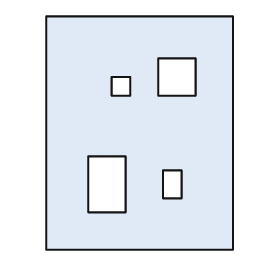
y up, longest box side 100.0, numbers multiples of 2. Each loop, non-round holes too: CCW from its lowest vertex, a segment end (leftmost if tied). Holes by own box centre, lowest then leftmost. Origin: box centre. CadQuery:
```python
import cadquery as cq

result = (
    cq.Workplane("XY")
    .moveTo(-40.0, -50.0)
    .lineTo(40.0, -50.0)
    .lineTo(40.0, 50.0)
    .lineTo(-40.0, 50.0)
    .close()
    .moveTo(-22.0, -34.0)
    .lineTo(-6.0, -34.0)
    .lineTo(-6.0, -10.0)
    .lineTo(-22.0, -10.0)
    .close()
    .moveTo(10.0, -28.0)
    .lineTo(18.0, -28.0)
    .lineTo(18.0, -16.0)
    .lineTo(10.0, -16.0)
    .close()
    .moveTo(-12.0, 16.0)
    .lineTo(-4.0, 16.0)
    .lineTo(-4.0, 24.0)
    .lineTo(-12.0, 24.0)
    .close()
    .moveTo(8.0, 16.0)
    .lineTo(24.0, 16.0)
    .lineTo(24.0, 32.0)
    .lineTo(8.0, 32.0)
    .close()
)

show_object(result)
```